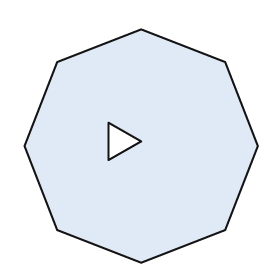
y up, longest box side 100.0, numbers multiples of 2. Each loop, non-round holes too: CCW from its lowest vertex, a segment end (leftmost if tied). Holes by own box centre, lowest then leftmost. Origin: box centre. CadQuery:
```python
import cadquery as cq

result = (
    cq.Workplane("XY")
    .moveTo(0.0, -50.0)
    .lineTo(36.0, -36.0)
    .lineTo(50.0, 0.0)
    .lineTo(36.0, 36.0)
    .lineTo(0.0, 50.0)
    .lineTo(-36.0, 36.0)
    .lineTo(-50.0, 0.0)
    .lineTo(-36.0, -36.0)
    .close()
    .moveTo(-14.0, -6.0)
    .lineTo(0.0, 2.0)
    .lineTo(-14.0, 10.0)
    .close()
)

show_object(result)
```